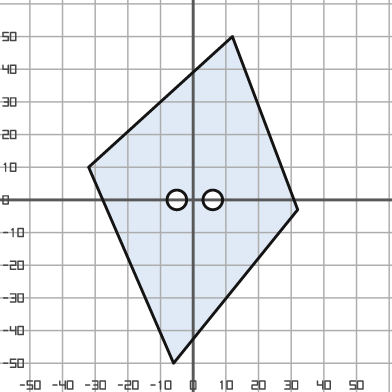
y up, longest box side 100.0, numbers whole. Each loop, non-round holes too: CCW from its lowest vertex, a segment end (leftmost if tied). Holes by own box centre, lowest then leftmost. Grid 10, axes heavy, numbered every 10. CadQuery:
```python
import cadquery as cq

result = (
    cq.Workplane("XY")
    .moveTo(-6.0, -50.0)
    .lineTo(32.0, -3.0)
    .lineTo(12.0, 50.0)
    .lineTo(-32.0, 10.0)
    .close()
    .moveTo(-5.0, 0.0)
    .circle(3.0)
    .moveTo(6.0, 0.0)
    .circle(3.0)
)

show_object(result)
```